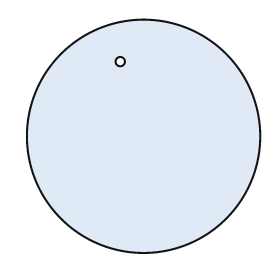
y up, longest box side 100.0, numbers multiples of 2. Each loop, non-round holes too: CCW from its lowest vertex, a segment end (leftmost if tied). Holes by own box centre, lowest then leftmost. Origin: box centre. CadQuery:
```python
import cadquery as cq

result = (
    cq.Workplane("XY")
    .moveTo(0.0, 0.0)
    .circle(50.0)
    .moveTo(-10.0, 32.0)
    .circle(2.0)
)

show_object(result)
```